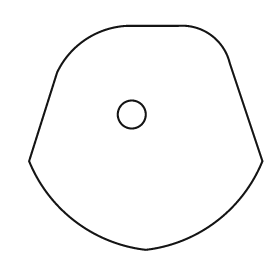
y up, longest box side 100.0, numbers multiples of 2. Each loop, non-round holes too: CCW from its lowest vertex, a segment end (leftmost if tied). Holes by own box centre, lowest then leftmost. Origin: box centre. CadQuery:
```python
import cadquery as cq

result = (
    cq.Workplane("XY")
    .moveTo(0.0, -48.0)
    .threePointArc((30.0, -36.0), (50.0, -10.0))
    .lineTo(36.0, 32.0)
    .threePointArc((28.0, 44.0), (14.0, 48.0))
    .lineTo(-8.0, 48.0)
    .threePointArc((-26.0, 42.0), (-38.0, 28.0))
    .lineTo(-50.0, -10.0)
    .threePointArc((-30.0, -36.0), (0.0, -48.0))
    .close()
    .moveTo(-6.0, 10.0)
    .circle(6.0)
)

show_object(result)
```